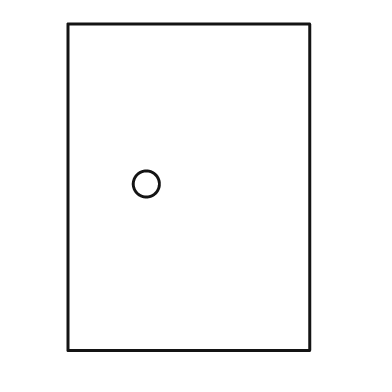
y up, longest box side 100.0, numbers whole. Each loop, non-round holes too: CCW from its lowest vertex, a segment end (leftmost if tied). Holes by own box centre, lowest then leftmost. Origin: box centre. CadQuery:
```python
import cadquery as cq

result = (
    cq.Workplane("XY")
    .moveTo(-37.0, -50.0)
    .lineTo(37.0, -50.0)
    .lineTo(37.0, 50.0)
    .lineTo(-37.0, 50.0)
    .close()
    .moveTo(-13.0, 1.0)
    .circle(4.0)
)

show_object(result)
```